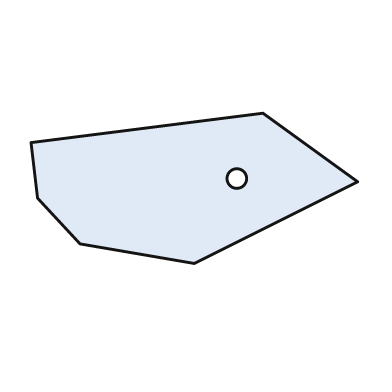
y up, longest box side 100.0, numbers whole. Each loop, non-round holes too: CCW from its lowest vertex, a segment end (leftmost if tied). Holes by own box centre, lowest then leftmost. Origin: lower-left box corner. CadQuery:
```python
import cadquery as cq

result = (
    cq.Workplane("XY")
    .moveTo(50.0, 0.0)
    .lineTo(100.0, 25.0)
    .lineTo(71.0, 46.0)
    .lineTo(0.0, 37.0)
    .lineTo(2.0, 20.0)
    .lineTo(15.0, 6.0)
    .close()
    .moveTo(63.0, 26.0)
    .circle(3.0)
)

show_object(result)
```